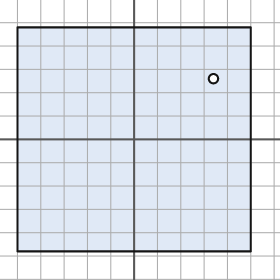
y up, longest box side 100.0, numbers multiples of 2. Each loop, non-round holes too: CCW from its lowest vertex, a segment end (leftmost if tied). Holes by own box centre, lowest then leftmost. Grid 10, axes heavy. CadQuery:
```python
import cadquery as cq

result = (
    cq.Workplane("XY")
    .moveTo(-50.0, -48.0)
    .lineTo(50.0, -48.0)
    .lineTo(50.0, 48.0)
    .lineTo(-50.0, 48.0)
    .close()
    .moveTo(34.0, 26.0)
    .circle(2.0)
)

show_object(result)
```